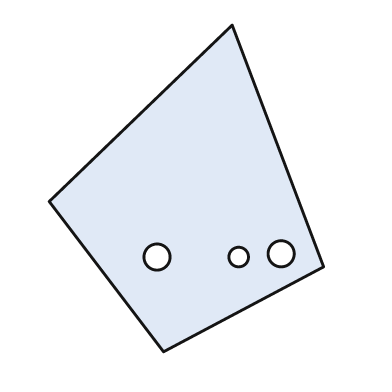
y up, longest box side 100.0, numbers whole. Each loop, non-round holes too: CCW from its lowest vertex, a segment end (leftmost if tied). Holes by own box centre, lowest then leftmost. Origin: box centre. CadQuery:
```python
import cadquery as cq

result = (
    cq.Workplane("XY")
    .moveTo(-7.0, -50.0)
    .lineTo(42.0, -24.0)
    .lineTo(14.0, 50.0)
    .lineTo(-42.0, -4.0)
    .close()
    .moveTo(-9.0, -21.0)
    .circle(4.0)
    .moveTo(16.0, -21.0)
    .circle(3.0)
    .moveTo(29.0, -20.0)
    .circle(4.0)
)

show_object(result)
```